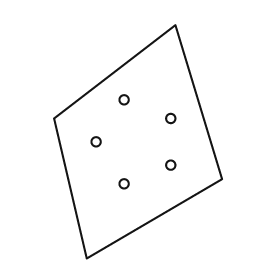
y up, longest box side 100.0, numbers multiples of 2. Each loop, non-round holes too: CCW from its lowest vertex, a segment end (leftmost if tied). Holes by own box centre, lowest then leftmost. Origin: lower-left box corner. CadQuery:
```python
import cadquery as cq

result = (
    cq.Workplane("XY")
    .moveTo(14.0, 0.0)
    .lineTo(72.0, 34.0)
    .lineTo(52.0, 100.0)
    .lineTo(0.0, 60.0)
    .close()
    .moveTo(30.0, 32.0)
    .circle(2.0)
    .moveTo(50.0, 40.0)
    .circle(2.0)
    .moveTo(18.0, 50.0)
    .circle(2.0)
    .moveTo(50.0, 60.0)
    .circle(2.0)
    .moveTo(30.0, 68.0)
    .circle(2.0)
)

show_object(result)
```